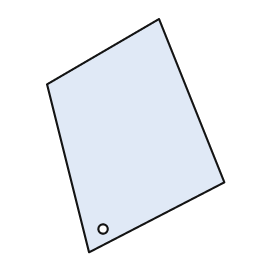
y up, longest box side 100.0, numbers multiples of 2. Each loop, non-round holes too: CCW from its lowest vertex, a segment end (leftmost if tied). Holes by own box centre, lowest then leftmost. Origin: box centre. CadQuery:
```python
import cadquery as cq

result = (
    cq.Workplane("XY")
    .moveTo(-20.0, -50.0)
    .lineTo(38.0, -20.0)
    .lineTo(10.0, 50.0)
    .lineTo(-38.0, 22.0)
    .close()
    .moveTo(-14.0, -40.0)
    .circle(2.0)
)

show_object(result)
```